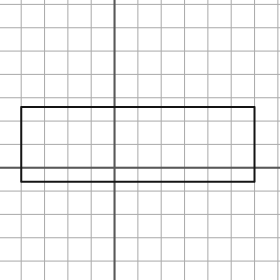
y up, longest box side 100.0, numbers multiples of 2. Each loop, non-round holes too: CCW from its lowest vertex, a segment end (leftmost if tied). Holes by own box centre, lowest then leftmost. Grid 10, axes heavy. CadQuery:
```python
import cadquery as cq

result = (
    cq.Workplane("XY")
    .moveTo(-40.0, -6.0)
    .lineTo(60.0, -6.0)
    .lineTo(60.0, 26.0)
    .lineTo(-40.0, 26.0)
    .close()
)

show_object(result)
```